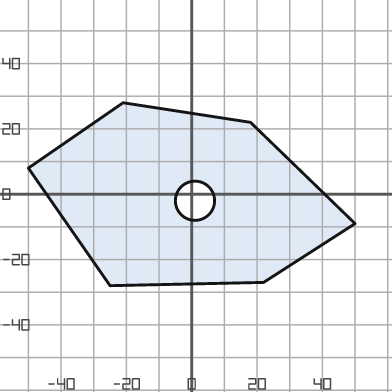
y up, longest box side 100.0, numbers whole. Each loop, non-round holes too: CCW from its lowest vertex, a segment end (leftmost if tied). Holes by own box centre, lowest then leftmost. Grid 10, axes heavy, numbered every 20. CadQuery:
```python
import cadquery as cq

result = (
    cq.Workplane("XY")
    .moveTo(-25.0, -28.0)
    .lineTo(22.0, -27.0)
    .lineTo(50.0, -9.0)
    .lineTo(18.0, 22.0)
    .lineTo(-21.0, 28.0)
    .lineTo(-50.0, 8.0)
    .close()
    .moveTo(1.0, -2.0)
    .circle(6.0)
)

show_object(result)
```